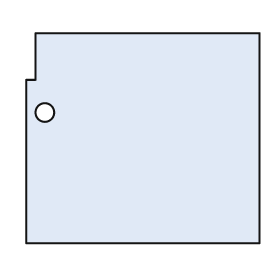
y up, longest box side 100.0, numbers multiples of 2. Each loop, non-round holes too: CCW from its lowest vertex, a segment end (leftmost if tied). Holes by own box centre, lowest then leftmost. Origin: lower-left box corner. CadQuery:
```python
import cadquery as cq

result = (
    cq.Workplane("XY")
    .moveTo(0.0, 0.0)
    .lineTo(100.0, 0.0)
    .lineTo(100.0, 90.0)
    .lineTo(4.0, 90.0)
    .lineTo(4.0, 70.0)
    .lineTo(0.0, 70.0)
    .close()
    .moveTo(8.0, 56.0)
    .circle(4.0)
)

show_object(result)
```